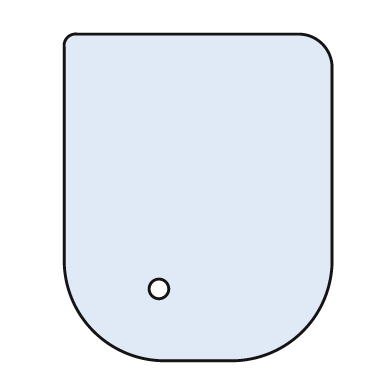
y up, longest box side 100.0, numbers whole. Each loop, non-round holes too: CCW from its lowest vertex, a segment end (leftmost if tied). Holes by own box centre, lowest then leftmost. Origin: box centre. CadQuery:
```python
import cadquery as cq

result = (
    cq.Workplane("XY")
    .moveTo(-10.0, -50.0)
    .lineTo(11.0, -50.0)
    .threePointArc((32.0, -41.0), (41.0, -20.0))
    .lineTo(41.0, 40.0)
    .threePointArc((38.0, 47.0), (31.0, 50.0))
    .lineTo(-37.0, 50.0)
    .threePointArc((-40.0, 49.0), (-41.0, 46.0))
    .lineTo(-41.0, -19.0)
    .threePointArc((-32.0, -41.0), (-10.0, -50.0))
    .close()
    .moveTo(-12.0, -28.0)
    .circle(3.0)
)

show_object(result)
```